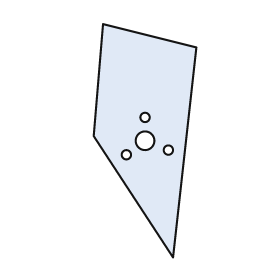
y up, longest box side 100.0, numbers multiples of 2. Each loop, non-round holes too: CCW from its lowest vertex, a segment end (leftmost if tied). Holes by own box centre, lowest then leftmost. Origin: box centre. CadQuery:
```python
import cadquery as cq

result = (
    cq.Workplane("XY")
    .moveTo(12.0, -50.0)
    .lineTo(22.0, 40.0)
    .lineTo(-18.0, 50.0)
    .lineTo(-22.0, 2.0)
    .close()
    .moveTo(-8.0, -6.0)
    .circle(2.0)
    .moveTo(10.0, -4.0)
    .circle(2.0)
    .moveTo(0.0, 0.0)
    .circle(4.0)
    .moveTo(0.0, 10.0)
    .circle(2.0)
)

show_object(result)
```